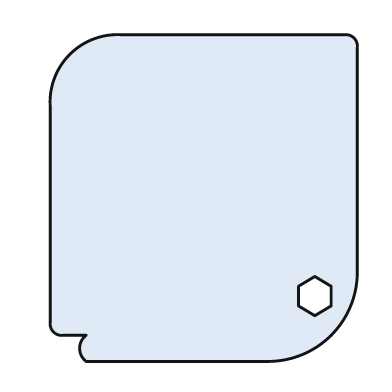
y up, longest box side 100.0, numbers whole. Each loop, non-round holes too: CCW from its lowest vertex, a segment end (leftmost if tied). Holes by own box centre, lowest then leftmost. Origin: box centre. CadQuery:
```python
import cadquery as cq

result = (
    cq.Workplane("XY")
    .moveTo(-36.0, -50.0)
    .lineTo(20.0, -50.0)
    .threePointArc((39.0, -42.0), (47.0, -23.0))
    .lineTo(47.0, 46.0)
    .threePointArc((46.0, 49.0), (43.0, 50.0))
    .lineTo(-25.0, 50.0)
    .threePointArc((-41.0, 44.0), (-47.0, 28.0))
    .lineTo(-47.0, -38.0)
    .threePointArc((-46.0, -41.0), (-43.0, -42.0))
    .lineTo(-36.0, -42.0)
    .threePointArc((-38.0, -46.0), (-36.0, -50.0))
    .close()
    .moveTo(34.0, -36.0)
    .lineTo(39.0, -33.0)
    .lineTo(39.0, -27.0)
    .lineTo(34.0, -24.0)
    .lineTo(29.0, -27.0)
    .lineTo(29.0, -33.0)
    .close()
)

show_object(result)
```